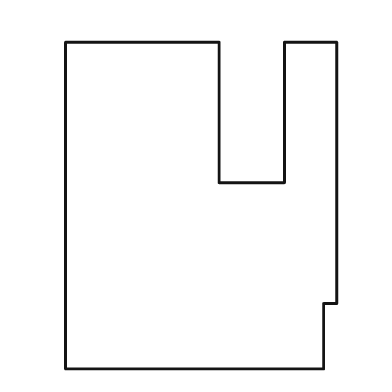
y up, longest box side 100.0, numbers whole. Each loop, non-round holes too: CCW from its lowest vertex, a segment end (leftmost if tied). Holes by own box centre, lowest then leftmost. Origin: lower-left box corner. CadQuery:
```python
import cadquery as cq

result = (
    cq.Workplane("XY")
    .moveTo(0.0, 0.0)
    .lineTo(79.0, 0.0)
    .lineTo(79.0, 20.0)
    .lineTo(83.0, 20.0)
    .lineTo(83.0, 100.0)
    .lineTo(67.0, 100.0)
    .lineTo(67.0, 57.0)
    .lineTo(47.0, 57.0)
    .lineTo(47.0, 100.0)
    .lineTo(0.0, 100.0)
    .close()
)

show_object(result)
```